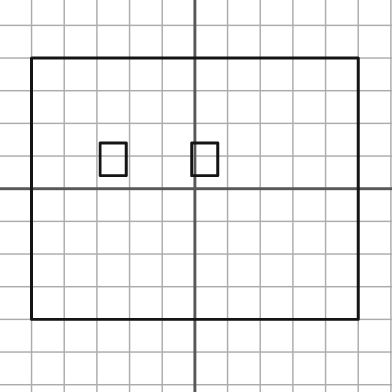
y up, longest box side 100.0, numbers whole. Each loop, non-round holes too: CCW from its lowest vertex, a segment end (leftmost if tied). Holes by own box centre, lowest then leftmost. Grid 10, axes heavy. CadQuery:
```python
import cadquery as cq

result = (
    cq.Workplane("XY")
    .moveTo(-50.0, -40.0)
    .lineTo(50.0, -40.0)
    .lineTo(50.0, 40.0)
    .lineTo(-50.0, 40.0)
    .close()
    .moveTo(-29.0, 4.0)
    .lineTo(-21.0, 4.0)
    .lineTo(-21.0, 14.0)
    .lineTo(-29.0, 14.0)
    .close()
    .moveTo(-1.0, 4.0)
    .lineTo(7.0, 4.0)
    .lineTo(7.0, 14.0)
    .lineTo(-1.0, 14.0)
    .close()
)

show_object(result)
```